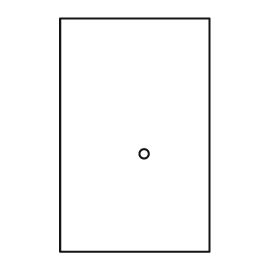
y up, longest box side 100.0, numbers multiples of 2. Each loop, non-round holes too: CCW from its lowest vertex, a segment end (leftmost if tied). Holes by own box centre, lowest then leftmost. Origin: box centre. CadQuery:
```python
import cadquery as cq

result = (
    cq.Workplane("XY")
    .moveTo(-32.0, -50.0)
    .lineTo(32.0, -50.0)
    .lineTo(32.0, 50.0)
    .lineTo(-32.0, 50.0)
    .close()
    .moveTo(4.0, -8.0)
    .circle(2.0)
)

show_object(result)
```